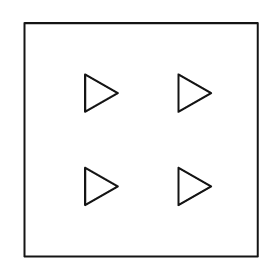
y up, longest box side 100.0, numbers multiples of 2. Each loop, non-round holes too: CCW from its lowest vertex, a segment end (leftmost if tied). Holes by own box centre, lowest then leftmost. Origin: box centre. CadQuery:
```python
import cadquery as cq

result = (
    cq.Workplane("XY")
    .moveTo(-50.0, -50.0)
    .lineTo(50.0, -50.0)
    .lineTo(50.0, 50.0)
    .lineTo(-50.0, 50.0)
    .close()
    .moveTo(-24.0, -28.0)
    .lineTo(-10.0, -20.0)
    .lineTo(-24.0, -12.0)
    .close()
    .moveTo(16.0, -28.0)
    .lineTo(30.0, -20.0)
    .lineTo(16.0, -12.0)
    .close()
    .moveTo(-24.0, 12.0)
    .lineTo(-10.0, 20.0)
    .lineTo(-24.0, 28.0)
    .close()
    .moveTo(16.0, 12.0)
    .lineTo(30.0, 20.0)
    .lineTo(16.0, 28.0)
    .close()
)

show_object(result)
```